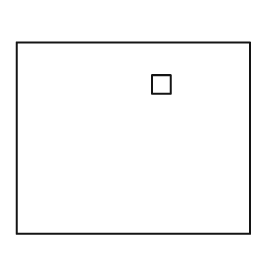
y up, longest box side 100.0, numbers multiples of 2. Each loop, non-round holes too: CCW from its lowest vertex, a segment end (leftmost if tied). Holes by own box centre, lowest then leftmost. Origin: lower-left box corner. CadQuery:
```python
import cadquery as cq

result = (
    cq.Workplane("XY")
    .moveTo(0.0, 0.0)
    .lineTo(100.0, 0.0)
    .lineTo(100.0, 82.0)
    .lineTo(0.0, 82.0)
    .close()
    .moveTo(58.0, 60.0)
    .lineTo(66.0, 60.0)
    .lineTo(66.0, 68.0)
    .lineTo(58.0, 68.0)
    .close()
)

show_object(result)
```